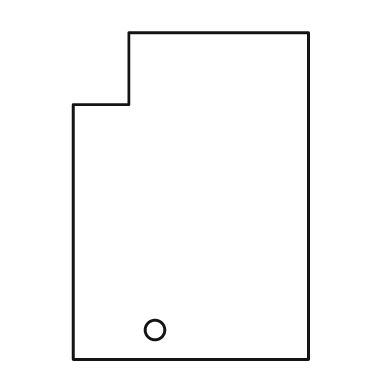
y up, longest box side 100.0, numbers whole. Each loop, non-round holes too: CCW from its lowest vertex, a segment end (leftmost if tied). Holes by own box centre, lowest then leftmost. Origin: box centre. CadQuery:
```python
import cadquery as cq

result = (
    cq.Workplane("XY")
    .moveTo(-36.0, -50.0)
    .lineTo(36.0, -50.0)
    .lineTo(36.0, 50.0)
    .lineTo(-19.0, 50.0)
    .lineTo(-19.0, 28.0)
    .lineTo(-36.0, 28.0)
    .close()
    .moveTo(-11.0, -41.0)
    .circle(3.0)
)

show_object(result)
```